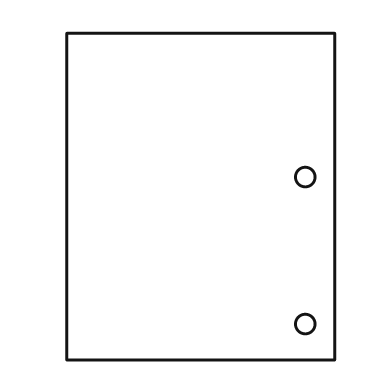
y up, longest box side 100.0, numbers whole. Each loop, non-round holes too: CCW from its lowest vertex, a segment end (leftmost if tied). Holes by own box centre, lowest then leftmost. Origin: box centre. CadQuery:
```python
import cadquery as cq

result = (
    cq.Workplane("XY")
    .moveTo(-41.0, -50.0)
    .lineTo(41.0, -50.0)
    .lineTo(41.0, 50.0)
    .lineTo(-41.0, 50.0)
    .close()
    .moveTo(32.0, -39.0)
    .circle(3.0)
    .moveTo(32.0, 6.0)
    .circle(3.0)
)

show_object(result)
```